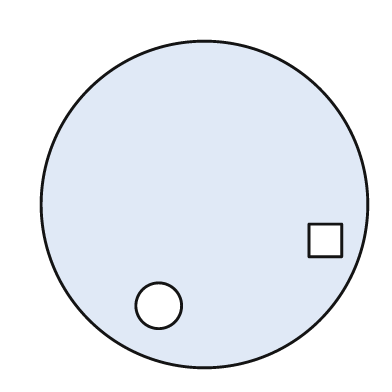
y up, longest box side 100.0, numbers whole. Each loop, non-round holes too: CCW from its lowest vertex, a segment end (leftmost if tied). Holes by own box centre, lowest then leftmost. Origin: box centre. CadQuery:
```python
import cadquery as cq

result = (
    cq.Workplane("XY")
    .moveTo(0.0, 0.0)
    .circle(50.0)
    .moveTo(-14.0, -31.0)
    .circle(7.0)
    .moveTo(32.0, -16.0)
    .lineTo(42.0, -16.0)
    .lineTo(42.0, -6.0)
    .lineTo(32.0, -6.0)
    .close()
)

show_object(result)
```